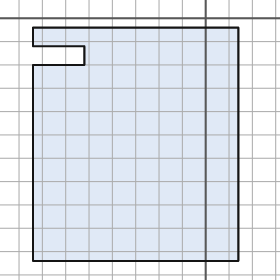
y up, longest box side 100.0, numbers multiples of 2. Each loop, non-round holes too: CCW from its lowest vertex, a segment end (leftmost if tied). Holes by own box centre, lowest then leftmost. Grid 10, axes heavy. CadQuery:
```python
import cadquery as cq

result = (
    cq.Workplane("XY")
    .moveTo(-74.0, -104.0)
    .lineTo(14.0, -104.0)
    .lineTo(14.0, -4.0)
    .lineTo(-74.0, -4.0)
    .lineTo(-74.0, -12.0)
    .lineTo(-52.0, -12.0)
    .lineTo(-52.0, -20.0)
    .lineTo(-74.0, -20.0)
    .close()
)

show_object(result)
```